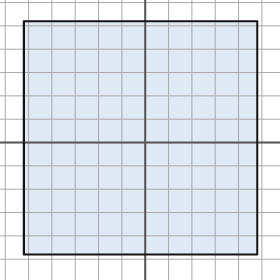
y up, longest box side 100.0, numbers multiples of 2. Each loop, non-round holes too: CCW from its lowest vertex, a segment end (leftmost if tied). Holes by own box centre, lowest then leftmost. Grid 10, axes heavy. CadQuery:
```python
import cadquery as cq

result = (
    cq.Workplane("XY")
    .moveTo(-52.0, -48.0)
    .lineTo(48.0, -48.0)
    .lineTo(48.0, 52.0)
    .lineTo(-52.0, 52.0)
    .close()
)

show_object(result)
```